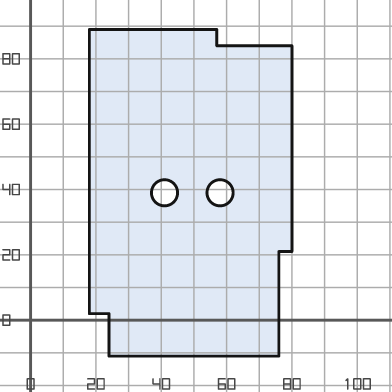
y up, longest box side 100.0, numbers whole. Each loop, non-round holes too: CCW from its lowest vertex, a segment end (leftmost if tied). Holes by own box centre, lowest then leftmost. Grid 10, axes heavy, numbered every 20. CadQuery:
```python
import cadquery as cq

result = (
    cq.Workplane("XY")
    .moveTo(24.0, -11.0)
    .lineTo(76.0, -11.0)
    .lineTo(76.0, 21.0)
    .lineTo(80.0, 21.0)
    .lineTo(80.0, 84.0)
    .lineTo(57.0, 84.0)
    .lineTo(57.0, 89.0)
    .lineTo(18.0, 89.0)
    .lineTo(18.0, 2.0)
    .lineTo(24.0, 2.0)
    .close()
    .moveTo(41.0, 39.0)
    .circle(4.0)
    .moveTo(58.0, 39.0)
    .circle(4.0)
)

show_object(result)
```